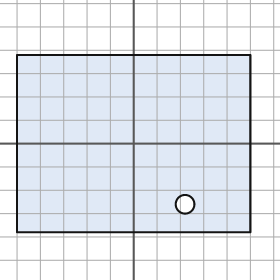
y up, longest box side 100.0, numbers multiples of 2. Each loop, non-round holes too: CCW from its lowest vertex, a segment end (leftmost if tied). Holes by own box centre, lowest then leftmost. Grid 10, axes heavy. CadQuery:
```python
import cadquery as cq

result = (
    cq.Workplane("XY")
    .moveTo(-50.0, -38.0)
    .lineTo(50.0, -38.0)
    .lineTo(50.0, 38.0)
    .lineTo(-50.0, 38.0)
    .close()
    .moveTo(22.0, -26.0)
    .circle(4.0)
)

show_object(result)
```